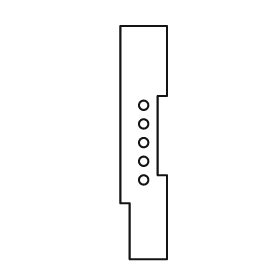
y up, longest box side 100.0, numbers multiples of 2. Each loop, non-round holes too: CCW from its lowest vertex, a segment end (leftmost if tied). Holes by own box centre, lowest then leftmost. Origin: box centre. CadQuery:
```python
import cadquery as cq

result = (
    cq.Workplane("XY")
    .moveTo(-6.0, -50.0)
    .lineTo(10.0, -50.0)
    .lineTo(10.0, -14.0)
    .lineTo(6.0, -14.0)
    .lineTo(6.0, 20.0)
    .lineTo(10.0, 20.0)
    .lineTo(10.0, 50.0)
    .lineTo(-10.0, 50.0)
    .lineTo(-10.0, -26.0)
    .lineTo(-6.0, -26.0)
    .close()
    .moveTo(0.0, -16.0)
    .circle(2.0)
    .moveTo(0.0, -8.0)
    .circle(2.0)
    .moveTo(0.0, 0.0)
    .circle(2.0)
    .moveTo(0.0, 8.0)
    .circle(2.0)
    .moveTo(0.0, 16.0)
    .circle(2.0)
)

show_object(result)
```